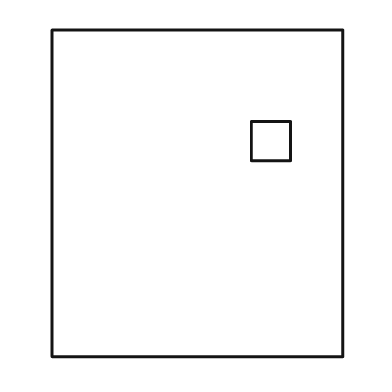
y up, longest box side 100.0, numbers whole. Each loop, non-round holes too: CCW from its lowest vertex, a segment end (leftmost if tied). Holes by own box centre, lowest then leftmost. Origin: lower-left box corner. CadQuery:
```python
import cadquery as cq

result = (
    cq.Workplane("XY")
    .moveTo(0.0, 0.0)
    .lineTo(89.0, 0.0)
    .lineTo(89.0, 100.0)
    .lineTo(0.0, 100.0)
    .close()
    .moveTo(61.0, 60.0)
    .lineTo(73.0, 60.0)
    .lineTo(73.0, 72.0)
    .lineTo(61.0, 72.0)
    .close()
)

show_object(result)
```